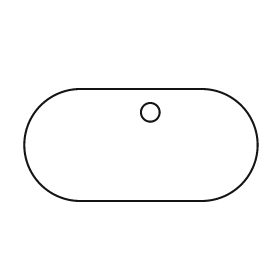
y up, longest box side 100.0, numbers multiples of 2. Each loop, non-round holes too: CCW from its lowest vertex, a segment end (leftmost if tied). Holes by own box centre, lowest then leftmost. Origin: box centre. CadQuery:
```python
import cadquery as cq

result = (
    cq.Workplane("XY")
    .moveTo(-26.0, -24.0)
    .lineTo(26.0, -24.0)
    .threePointArc((50.0, 0.0), (26.0, 24.0))
    .lineTo(-26.0, 24.0)
    .threePointArc((-50.0, 0.0), (-26.0, -24.0))
    .close()
    .moveTo(4.0, 14.0)
    .circle(4.0)
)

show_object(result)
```